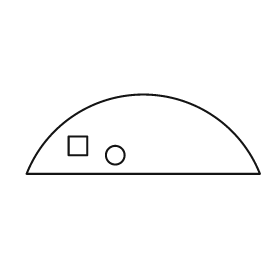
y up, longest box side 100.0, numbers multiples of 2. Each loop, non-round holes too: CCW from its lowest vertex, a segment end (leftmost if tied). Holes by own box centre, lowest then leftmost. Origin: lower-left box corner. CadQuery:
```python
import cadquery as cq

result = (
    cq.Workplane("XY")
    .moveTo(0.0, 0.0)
    .lineTo(100.0, 0.0)
    .threePointArc((50.0, 34.0), (0.0, 0.0))
    .close()
    .moveTo(38.0, 8.0)
    .circle(4.0)
    .moveTo(18.0, 8.0)
    .lineTo(26.0, 8.0)
    .lineTo(26.0, 16.0)
    .lineTo(18.0, 16.0)
    .close()
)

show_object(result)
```